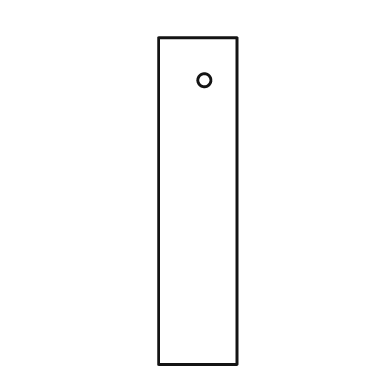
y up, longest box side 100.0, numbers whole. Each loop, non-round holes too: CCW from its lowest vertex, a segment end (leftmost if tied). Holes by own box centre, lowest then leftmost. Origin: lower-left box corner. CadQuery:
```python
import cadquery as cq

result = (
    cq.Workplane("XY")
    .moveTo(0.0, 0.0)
    .lineTo(24.0, 0.0)
    .lineTo(24.0, 100.0)
    .lineTo(0.0, 100.0)
    .close()
    .moveTo(14.0, 87.0)
    .circle(2.0)
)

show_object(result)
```